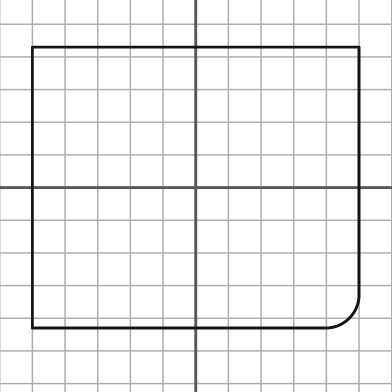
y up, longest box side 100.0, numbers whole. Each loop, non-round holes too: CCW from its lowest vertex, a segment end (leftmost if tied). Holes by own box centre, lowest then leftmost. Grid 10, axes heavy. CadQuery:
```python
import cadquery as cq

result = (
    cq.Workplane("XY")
    .moveTo(-50.0, -43.0)
    .lineTo(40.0, -43.0)
    .threePointArc((47.0, -40.0), (50.0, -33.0))
    .lineTo(50.0, 43.0)
    .lineTo(-50.0, 43.0)
    .close()
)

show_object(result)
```